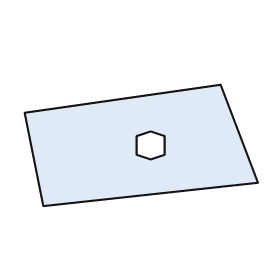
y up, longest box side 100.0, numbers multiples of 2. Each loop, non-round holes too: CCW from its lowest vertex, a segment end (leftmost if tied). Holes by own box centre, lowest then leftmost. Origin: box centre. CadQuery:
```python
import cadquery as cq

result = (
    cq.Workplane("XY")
    .moveTo(-42.0, -26.0)
    .lineTo(50.0, -16.0)
    .lineTo(34.0, 26.0)
    .lineTo(-50.0, 14.0)
    .close()
    .moveTo(4.0, -6.0)
    .lineTo(10.0, -4.0)
    .lineTo(10.0, 4.0)
    .lineTo(4.0, 6.0)
    .lineTo(-2.0, 4.0)
    .lineTo(-2.0, -4.0)
    .close()
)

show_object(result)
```